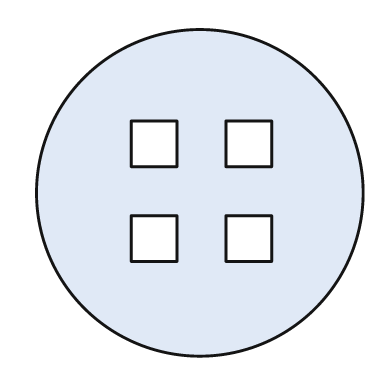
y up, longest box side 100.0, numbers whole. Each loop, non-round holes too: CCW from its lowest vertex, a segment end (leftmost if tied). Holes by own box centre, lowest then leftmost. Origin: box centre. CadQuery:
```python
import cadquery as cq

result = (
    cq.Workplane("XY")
    .moveTo(0.0, 0.0)
    .circle(50.0)
    .moveTo(-21.0, -21.0)
    .lineTo(-7.0, -21.0)
    .lineTo(-7.0, -7.0)
    .lineTo(-21.0, -7.0)
    .close()
    .moveTo(8.0, -21.0)
    .lineTo(22.0, -21.0)
    .lineTo(22.0, -7.0)
    .lineTo(8.0, -7.0)
    .close()
    .moveTo(-21.0, 8.0)
    .lineTo(-7.0, 8.0)
    .lineTo(-7.0, 22.0)
    .lineTo(-21.0, 22.0)
    .close()
    .moveTo(8.0, 8.0)
    .lineTo(22.0, 8.0)
    .lineTo(22.0, 22.0)
    .lineTo(8.0, 22.0)
    .close()
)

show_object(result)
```